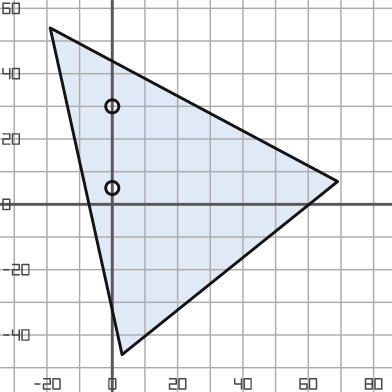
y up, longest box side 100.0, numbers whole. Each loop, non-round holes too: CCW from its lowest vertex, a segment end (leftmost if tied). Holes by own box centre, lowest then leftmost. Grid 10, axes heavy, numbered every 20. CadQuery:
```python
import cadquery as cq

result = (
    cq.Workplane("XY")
    .moveTo(3.0, -46.0)
    .lineTo(69.0, 7.0)
    .lineTo(-19.0, 54.0)
    .close()
    .moveTo(0.0, 5.0)
    .circle(2.0)
    .moveTo(0.0, 30.0)
    .circle(2.0)
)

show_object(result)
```